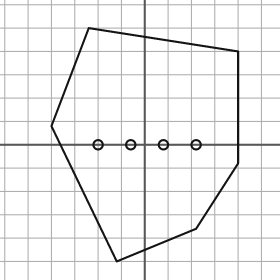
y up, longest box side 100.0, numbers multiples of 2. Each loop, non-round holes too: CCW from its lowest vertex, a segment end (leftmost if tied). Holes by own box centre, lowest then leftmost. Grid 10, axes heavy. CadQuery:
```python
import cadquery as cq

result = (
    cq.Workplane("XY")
    .moveTo(-12.0, -50.0)
    .lineTo(22.0, -36.0)
    .lineTo(40.0, -8.0)
    .lineTo(40.0, 40.0)
    .lineTo(-24.0, 50.0)
    .lineTo(-40.0, 8.0)
    .close()
    .moveTo(-20.0, 0.0)
    .circle(2.0)
    .moveTo(-6.0, 0.0)
    .circle(2.0)
    .moveTo(8.0, 0.0)
    .circle(2.0)
    .moveTo(22.0, 0.0)
    .circle(2.0)
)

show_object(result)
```